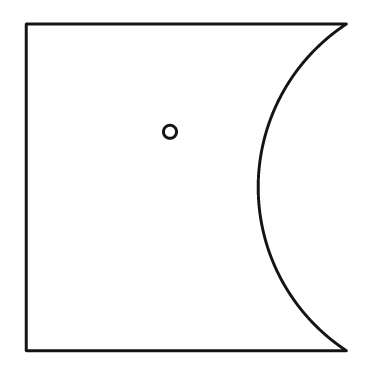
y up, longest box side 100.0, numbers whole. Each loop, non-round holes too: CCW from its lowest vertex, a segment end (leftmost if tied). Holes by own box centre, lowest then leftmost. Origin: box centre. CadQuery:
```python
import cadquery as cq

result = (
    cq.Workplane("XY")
    .moveTo(-49.0, -50.0)
    .lineTo(49.0, -50.0)
    .threePointArc((22.0, 0.0), (49.0, 50.0))
    .lineTo(-49.0, 50.0)
    .close()
    .moveTo(-5.0, 17.0)
    .circle(2.0)
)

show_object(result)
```